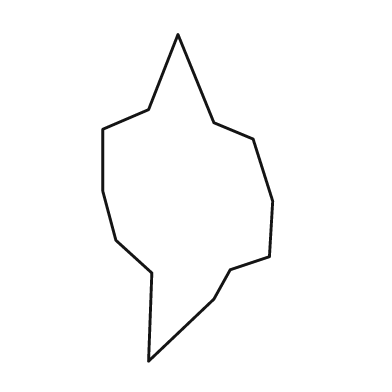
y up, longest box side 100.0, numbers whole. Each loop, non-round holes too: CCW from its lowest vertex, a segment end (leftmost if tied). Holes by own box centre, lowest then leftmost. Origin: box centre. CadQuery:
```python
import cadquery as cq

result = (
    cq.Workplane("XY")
    .moveTo(-12.0, -50.0)
    .lineTo(8.0, -31.0)
    .lineTo(13.0, -22.0)
    .lineTo(25.0, -18.0)
    .lineTo(26.0, -1.0)
    .lineTo(20.0, 18.0)
    .lineTo(8.0, 23.0)
    .lineTo(-3.0, 50.0)
    .lineTo(-12.0, 27.0)
    .lineTo(-26.0, 21.0)
    .lineTo(-26.0, 2.0)
    .lineTo(-22.0, -13.0)
    .lineTo(-11.0, -23.0)
    .close()
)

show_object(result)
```